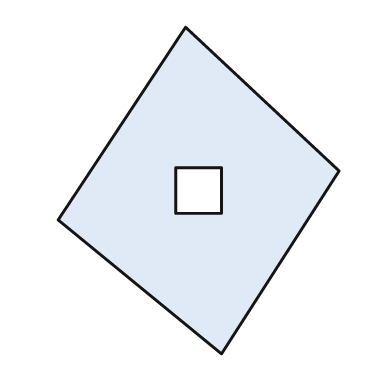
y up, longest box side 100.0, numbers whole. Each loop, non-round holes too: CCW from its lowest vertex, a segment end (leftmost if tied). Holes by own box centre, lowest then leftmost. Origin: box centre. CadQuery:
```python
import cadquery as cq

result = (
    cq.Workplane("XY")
    .moveTo(7.0, -50.0)
    .lineTo(43.0, 6.0)
    .lineTo(-4.0, 50.0)
    .lineTo(-43.0, -9.0)
    .close()
    .moveTo(-7.0, -7.0)
    .lineTo(7.0, -7.0)
    .lineTo(7.0, 7.0)
    .lineTo(-7.0, 7.0)
    .close()
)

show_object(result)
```